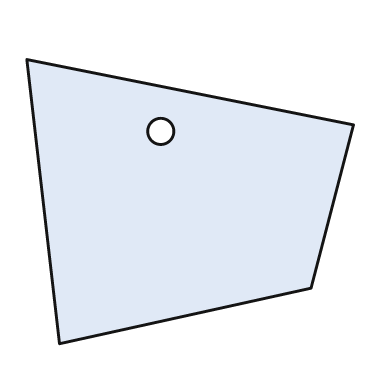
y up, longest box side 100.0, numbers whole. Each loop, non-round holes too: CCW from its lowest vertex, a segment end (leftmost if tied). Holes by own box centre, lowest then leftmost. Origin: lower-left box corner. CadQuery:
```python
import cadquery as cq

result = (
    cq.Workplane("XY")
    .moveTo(10.0, 0.0)
    .lineTo(87.0, 17.0)
    .lineTo(100.0, 67.0)
    .lineTo(0.0, 87.0)
    .close()
    .moveTo(41.0, 65.0)
    .circle(4.0)
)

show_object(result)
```